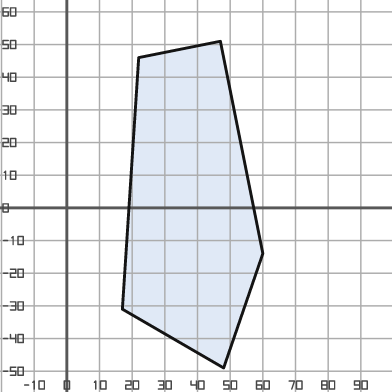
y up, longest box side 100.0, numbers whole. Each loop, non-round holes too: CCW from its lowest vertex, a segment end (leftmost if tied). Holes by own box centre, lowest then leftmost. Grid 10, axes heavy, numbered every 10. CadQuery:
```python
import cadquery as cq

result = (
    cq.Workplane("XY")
    .moveTo(48.0, -49.0)
    .lineTo(60.0, -14.0)
    .lineTo(47.0, 51.0)
    .lineTo(22.0, 46.0)
    .lineTo(17.0, -31.0)
    .close()
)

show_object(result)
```